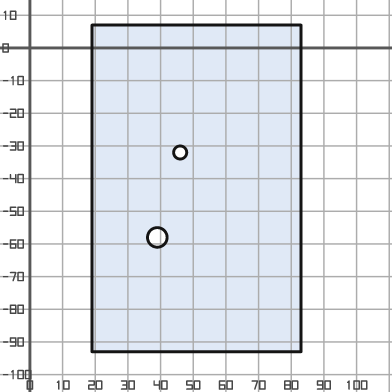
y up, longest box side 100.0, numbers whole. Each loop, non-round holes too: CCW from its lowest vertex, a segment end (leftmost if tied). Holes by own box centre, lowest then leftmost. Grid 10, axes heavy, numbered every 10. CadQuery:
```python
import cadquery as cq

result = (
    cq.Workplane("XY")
    .moveTo(19.0, -93.0)
    .lineTo(83.0, -93.0)
    .lineTo(83.0, 7.0)
    .lineTo(19.0, 7.0)
    .close()
    .moveTo(39.0, -58.0)
    .circle(3.0)
    .moveTo(46.0, -32.0)
    .circle(2.0)
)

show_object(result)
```